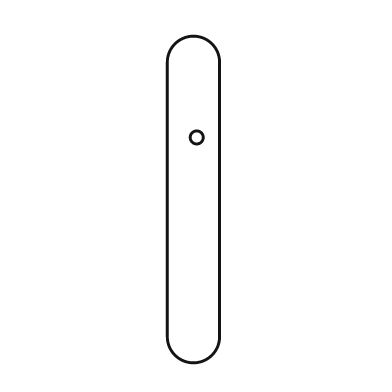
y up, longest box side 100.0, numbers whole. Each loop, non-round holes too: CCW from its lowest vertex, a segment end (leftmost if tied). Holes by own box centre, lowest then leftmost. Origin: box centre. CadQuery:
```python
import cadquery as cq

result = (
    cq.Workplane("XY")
    .moveTo(-8.0, -42.0)
    .threePointArc((0.0, -50.0), (8.0, -42.0))
    .lineTo(8.0, 42.0)
    .threePointArc((0.0, 50.0), (-8.0, 42.0))
    .close()
    .moveTo(1.0, 19.0)
    .circle(2.0)
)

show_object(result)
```